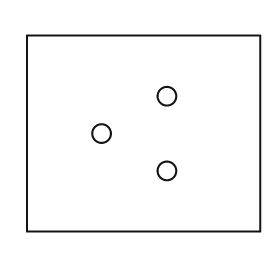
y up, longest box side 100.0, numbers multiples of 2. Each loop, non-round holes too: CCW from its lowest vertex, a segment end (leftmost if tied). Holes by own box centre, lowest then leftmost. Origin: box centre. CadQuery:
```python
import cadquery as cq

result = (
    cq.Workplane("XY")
    .moveTo(-50.0, -42.0)
    .lineTo(50.0, -42.0)
    .lineTo(50.0, 42.0)
    .lineTo(-50.0, 42.0)
    .close()
    .moveTo(10.0, -16.0)
    .circle(4.0)
    .moveTo(-18.0, 0.0)
    .circle(4.0)
    .moveTo(10.0, 16.0)
    .circle(4.0)
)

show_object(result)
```